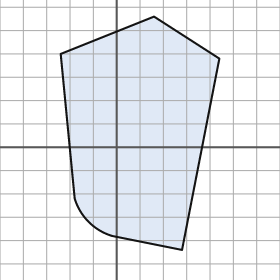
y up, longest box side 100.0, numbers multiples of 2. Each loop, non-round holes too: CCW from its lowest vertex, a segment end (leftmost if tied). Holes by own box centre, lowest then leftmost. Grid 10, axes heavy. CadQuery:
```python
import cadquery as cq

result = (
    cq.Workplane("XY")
    .moveTo(28.0, -44.0)
    .lineTo(44.0, 38.0)
    .lineTo(16.0, 56.0)
    .lineTo(-24.0, 40.0)
    .lineTo(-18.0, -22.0)
    .threePointArc((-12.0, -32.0), (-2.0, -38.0))
    .close()
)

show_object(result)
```